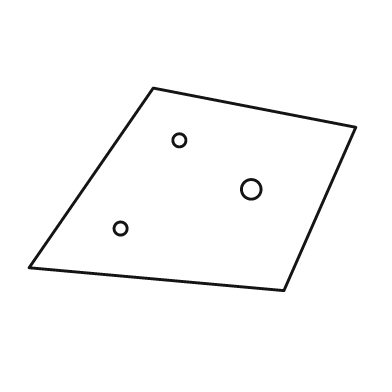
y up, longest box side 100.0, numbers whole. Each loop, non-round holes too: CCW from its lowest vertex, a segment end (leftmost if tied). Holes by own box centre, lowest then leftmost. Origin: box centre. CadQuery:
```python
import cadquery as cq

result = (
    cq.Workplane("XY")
    .moveTo(28.0, -31.0)
    .lineTo(50.0, 19.0)
    .lineTo(-12.0, 31.0)
    .lineTo(-50.0, -24.0)
    .close()
    .moveTo(-22.0, -12.0)
    .circle(2.0)
    .moveTo(18.0, 0.0)
    .circle(3.0)
    .moveTo(-4.0, 15.0)
    .circle(2.0)
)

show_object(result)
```